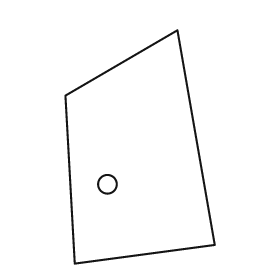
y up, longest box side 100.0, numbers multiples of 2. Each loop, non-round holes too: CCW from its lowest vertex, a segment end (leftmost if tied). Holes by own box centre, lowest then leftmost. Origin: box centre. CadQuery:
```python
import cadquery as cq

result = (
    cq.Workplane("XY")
    .moveTo(-28.0, -50.0)
    .lineTo(32.0, -42.0)
    .lineTo(16.0, 50.0)
    .lineTo(-32.0, 22.0)
    .close()
    .moveTo(-14.0, -16.0)
    .circle(4.0)
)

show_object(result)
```